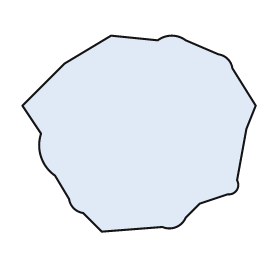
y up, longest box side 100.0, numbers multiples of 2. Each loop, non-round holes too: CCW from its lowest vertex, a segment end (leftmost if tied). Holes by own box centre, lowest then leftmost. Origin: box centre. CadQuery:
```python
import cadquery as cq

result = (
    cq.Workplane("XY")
    .moveTo(-16.0, -42.0)
    .lineTo(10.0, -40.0)
    .threePointArc((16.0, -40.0), (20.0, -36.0))
    .lineTo(26.0, -30.0)
    .lineTo(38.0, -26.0)
    .threePointArc((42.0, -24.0), (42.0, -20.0))
    .lineTo(46.0, 2.0)
    .lineTo(50.0, 12.0)
    .lineTo(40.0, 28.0)
    .threePointArc((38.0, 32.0), (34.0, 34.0))
    .lineTo(20.0, 40.0)
    .threePointArc((14.0, 42.0), (8.0, 40.0))
    .lineTo(-12.0, 42.0)
    .lineTo(-32.0, 30.0)
    .lineTo(-50.0, 12.0)
    .lineTo(-42.0, 0.0)
    .threePointArc((-42.0, -10.0), (-36.0, -18.0))
    .lineTo(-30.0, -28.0)
    .threePointArc((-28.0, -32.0), (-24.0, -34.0))
    .close()
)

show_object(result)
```